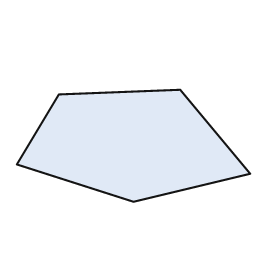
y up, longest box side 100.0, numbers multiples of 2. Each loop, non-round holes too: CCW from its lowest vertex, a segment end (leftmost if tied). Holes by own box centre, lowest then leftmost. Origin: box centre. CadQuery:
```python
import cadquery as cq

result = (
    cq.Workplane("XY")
    .moveTo(0.0, -24.0)
    .lineTo(50.0, -12.0)
    .lineTo(20.0, 24.0)
    .lineTo(-32.0, 22.0)
    .lineTo(-50.0, -8.0)
    .close()
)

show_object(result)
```